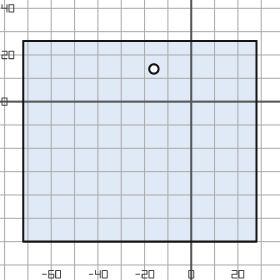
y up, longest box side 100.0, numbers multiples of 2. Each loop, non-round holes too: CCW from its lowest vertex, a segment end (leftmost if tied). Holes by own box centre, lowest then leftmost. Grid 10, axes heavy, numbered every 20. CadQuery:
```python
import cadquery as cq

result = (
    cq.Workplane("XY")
    .moveTo(-72.0, -60.0)
    .lineTo(28.0, -60.0)
    .lineTo(28.0, 26.0)
    .lineTo(-72.0, 26.0)
    .close()
    .moveTo(-16.0, 14.0)
    .circle(2.0)
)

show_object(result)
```